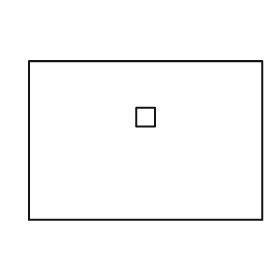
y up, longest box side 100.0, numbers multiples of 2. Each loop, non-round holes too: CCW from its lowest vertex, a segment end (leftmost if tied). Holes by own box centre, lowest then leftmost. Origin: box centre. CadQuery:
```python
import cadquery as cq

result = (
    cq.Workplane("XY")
    .moveTo(-50.0, -34.0)
    .lineTo(50.0, -34.0)
    .lineTo(50.0, 34.0)
    .lineTo(-50.0, 34.0)
    .close()
    .moveTo(-4.0, 6.0)
    .lineTo(4.0, 6.0)
    .lineTo(4.0, 14.0)
    .lineTo(-4.0, 14.0)
    .close()
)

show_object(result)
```